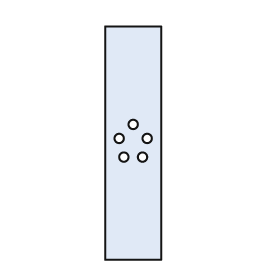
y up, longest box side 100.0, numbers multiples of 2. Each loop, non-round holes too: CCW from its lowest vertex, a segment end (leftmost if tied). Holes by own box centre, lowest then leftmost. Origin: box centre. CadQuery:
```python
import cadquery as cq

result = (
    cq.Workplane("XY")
    .moveTo(-12.0, -50.0)
    .lineTo(12.0, -50.0)
    .lineTo(12.0, 50.0)
    .lineTo(-12.0, 50.0)
    .close()
    .moveTo(-4.0, -6.0)
    .circle(2.0)
    .moveTo(4.0, -6.0)
    .circle(2.0)
    .moveTo(-6.0, 2.0)
    .circle(2.0)
    .moveTo(6.0, 2.0)
    .circle(2.0)
    .moveTo(0.0, 8.0)
    .circle(2.0)
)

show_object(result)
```